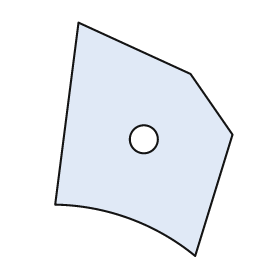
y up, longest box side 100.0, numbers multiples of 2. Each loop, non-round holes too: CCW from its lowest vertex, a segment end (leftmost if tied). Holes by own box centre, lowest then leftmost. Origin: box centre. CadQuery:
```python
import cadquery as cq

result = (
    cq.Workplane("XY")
    .moveTo(22.0, -50.0)
    .lineTo(38.0, 2.0)
    .lineTo(20.0, 28.0)
    .lineTo(-28.0, 50.0)
    .lineTo(-38.0, -28.0)
    .threePointArc((-6.0, -34.0), (22.0, -50.0))
    .close()
    .moveTo(0.0, 0.0)
    .circle(6.0)
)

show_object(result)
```